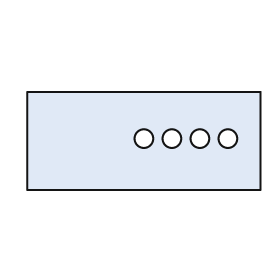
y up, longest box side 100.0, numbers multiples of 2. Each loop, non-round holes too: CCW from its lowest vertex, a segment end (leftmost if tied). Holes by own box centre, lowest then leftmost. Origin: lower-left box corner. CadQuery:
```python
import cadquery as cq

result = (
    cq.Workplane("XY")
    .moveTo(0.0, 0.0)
    .lineTo(100.0, 0.0)
    .lineTo(100.0, 42.0)
    .lineTo(0.0, 42.0)
    .close()
    .moveTo(50.0, 22.0)
    .circle(4.0)
    .moveTo(62.0, 22.0)
    .circle(4.0)
    .moveTo(74.0, 22.0)
    .circle(4.0)
    .moveTo(86.0, 22.0)
    .circle(4.0)
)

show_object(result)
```